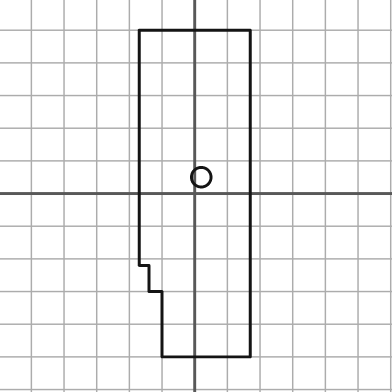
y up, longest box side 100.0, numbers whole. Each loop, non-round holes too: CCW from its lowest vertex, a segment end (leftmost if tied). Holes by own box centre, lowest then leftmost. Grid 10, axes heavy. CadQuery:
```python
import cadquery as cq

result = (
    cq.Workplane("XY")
    .moveTo(-10.0, -50.0)
    .lineTo(17.0, -50.0)
    .lineTo(17.0, 50.0)
    .lineTo(-17.0, 50.0)
    .lineTo(-17.0, -22.0)
    .lineTo(-14.0, -22.0)
    .lineTo(-14.0, -30.0)
    .lineTo(-10.0, -30.0)
    .close()
    .moveTo(2.0, 5.0)
    .circle(3.0)
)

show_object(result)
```